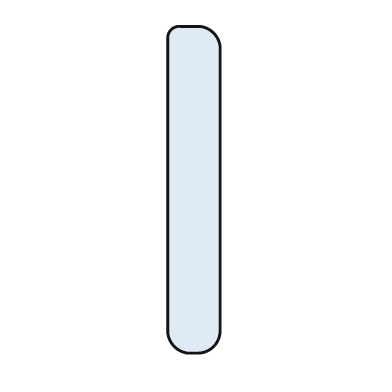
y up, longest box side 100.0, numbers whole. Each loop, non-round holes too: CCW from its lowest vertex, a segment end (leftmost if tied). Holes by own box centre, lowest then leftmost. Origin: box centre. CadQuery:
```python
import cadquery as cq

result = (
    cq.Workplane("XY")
    .moveTo(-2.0, -50.0)
    .lineTo(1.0, -50.0)
    .threePointArc((6.0, -48.0), (8.0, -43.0))
    .lineTo(8.0, 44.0)
    .threePointArc((6.0, 48.0), (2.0, 50.0))
    .lineTo(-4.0, 50.0)
    .threePointArc((-7.0, 49.0), (-8.0, 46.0))
    .lineTo(-8.0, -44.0)
    .threePointArc((-6.0, -48.0), (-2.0, -50.0))
    .close()
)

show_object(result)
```